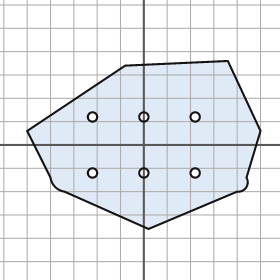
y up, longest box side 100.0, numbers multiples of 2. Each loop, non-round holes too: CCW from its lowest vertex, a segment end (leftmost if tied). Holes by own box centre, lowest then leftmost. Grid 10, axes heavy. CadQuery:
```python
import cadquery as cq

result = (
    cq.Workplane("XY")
    .moveTo(2.0, -36.0)
    .lineTo(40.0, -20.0)
    .threePointArc((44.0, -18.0), (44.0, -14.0))
    .lineTo(50.0, 6.0)
    .lineTo(36.0, 36.0)
    .lineTo(-8.0, 34.0)
    .lineTo(-50.0, 6.0)
    .lineTo(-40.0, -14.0)
    .threePointArc((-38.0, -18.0), (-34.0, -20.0))
    .close()
    .moveTo(-22.0, -12.0)
    .circle(2.0)
    .moveTo(0.0, -12.0)
    .circle(2.0)
    .moveTo(22.0, -12.0)
    .circle(2.0)
    .moveTo(-22.0, 12.0)
    .circle(2.0)
    .moveTo(0.0, 12.0)
    .circle(2.0)
    .moveTo(22.0, 12.0)
    .circle(2.0)
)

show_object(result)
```